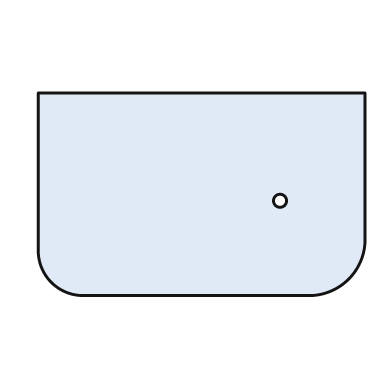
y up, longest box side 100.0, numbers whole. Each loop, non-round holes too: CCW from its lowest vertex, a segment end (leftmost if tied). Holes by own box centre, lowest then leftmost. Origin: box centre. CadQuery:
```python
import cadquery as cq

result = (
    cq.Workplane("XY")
    .moveTo(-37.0, -31.0)
    .lineTo(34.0, -31.0)
    .threePointArc((45.0, -26.0), (50.0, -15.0))
    .lineTo(50.0, 31.0)
    .lineTo(-50.0, 31.0)
    .lineTo(-50.0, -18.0)
    .threePointArc((-46.0, -27.0), (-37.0, -31.0))
    .close()
    .moveTo(24.0, -2.0)
    .circle(2.0)
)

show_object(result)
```